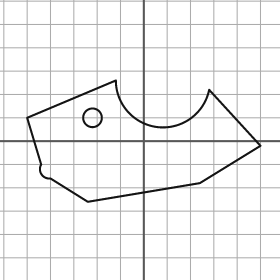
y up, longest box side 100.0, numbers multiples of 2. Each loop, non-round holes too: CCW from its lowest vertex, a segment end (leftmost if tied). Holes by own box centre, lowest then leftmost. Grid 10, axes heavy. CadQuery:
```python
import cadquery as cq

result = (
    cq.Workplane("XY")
    .moveTo(-24.0, -26.0)
    .lineTo(24.0, -18.0)
    .lineTo(50.0, -2.0)
    .lineTo(28.0, 22.0)
    .threePointArc((6.0, 6.0), (-12.0, 26.0))
    .lineTo(-50.0, 10.0)
    .lineTo(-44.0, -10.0)
    .threePointArc((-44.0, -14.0), (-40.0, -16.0))
    .close()
    .moveTo(-22.0, 10.0)
    .circle(4.0)
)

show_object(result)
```